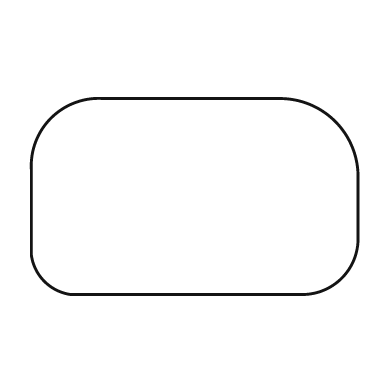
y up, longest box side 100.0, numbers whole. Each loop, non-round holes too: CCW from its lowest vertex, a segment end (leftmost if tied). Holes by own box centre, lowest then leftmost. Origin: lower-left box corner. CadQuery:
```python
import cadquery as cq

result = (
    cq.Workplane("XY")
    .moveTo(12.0, 0.0)
    .lineTo(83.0, 0.0)
    .threePointArc((95.0, 5.0), (100.0, 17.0))
    .lineTo(100.0, 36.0)
    .threePointArc((93.0, 53.0), (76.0, 60.0))
    .lineTo(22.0, 60.0)
    .threePointArc((6.0, 54.0), (0.0, 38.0))
    .lineTo(0.0, 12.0)
    .threePointArc((4.0, 4.0), (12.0, 0.0))
    .close()
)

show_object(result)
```